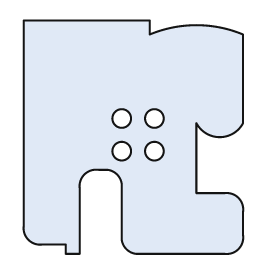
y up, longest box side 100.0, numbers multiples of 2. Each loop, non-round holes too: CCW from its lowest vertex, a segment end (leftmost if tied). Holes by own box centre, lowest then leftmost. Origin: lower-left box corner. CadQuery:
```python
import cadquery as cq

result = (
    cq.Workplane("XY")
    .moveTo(18.0, 0.0)
    .lineTo(24.0, 0.0)
    .lineTo(24.0, 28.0)
    .threePointArc((26.0, 34.0), (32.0, 36.0))
    .lineTo(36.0, 36.0)
    .threePointArc((40.0, 34.0), (42.0, 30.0))
    .lineTo(42.0, 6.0)
    .threePointArc((44.0, 2.0), (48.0, 0.0))
    .lineTo(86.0, 0.0)
    .threePointArc((92.0, 2.0), (94.0, 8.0))
    .lineTo(94.0, 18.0)
    .threePointArc((92.0, 24.0), (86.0, 26.0))
    .lineTo(74.0, 26.0)
    .lineTo(74.0, 56.0)
    .threePointArc((84.0, 50.0), (94.0, 56.0))
    .lineTo(94.0, 94.0)
    .threePointArc((74.0, 98.0), (54.0, 94.0))
    .lineTo(54.0, 100.0)
    .lineTo(0.0, 100.0)
    .lineTo(0.0, 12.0)
    .threePointArc((2.0, 6.0), (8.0, 4.0))
    .lineTo(18.0, 4.0)
    .close()
    .moveTo(42.0, 44.0)
    .circle(4.0)
    .moveTo(56.0, 44.0)
    .circle(4.0)
    .moveTo(42.0, 58.0)
    .circle(4.0)
    .moveTo(56.0, 58.0)
    .circle(4.0)
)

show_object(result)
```